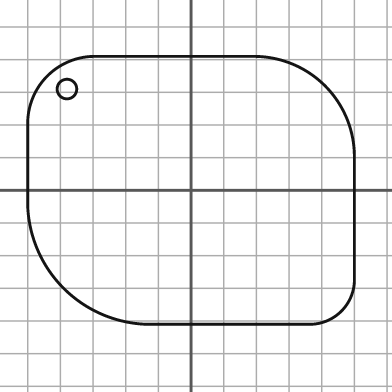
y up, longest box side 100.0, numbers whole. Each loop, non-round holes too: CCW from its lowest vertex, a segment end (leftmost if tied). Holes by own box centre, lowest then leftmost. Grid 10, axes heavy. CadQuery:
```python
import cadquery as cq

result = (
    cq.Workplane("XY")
    .moveTo(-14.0, -41.0)
    .lineTo(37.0, -41.0)
    .threePointArc((46.0, -37.0), (50.0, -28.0))
    .lineTo(50.0, 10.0)
    .threePointArc((41.0, 32.0), (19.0, 41.0))
    .lineTo(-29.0, 41.0)
    .threePointArc((-44.0, 35.0), (-50.0, 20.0))
    .lineTo(-50.0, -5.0)
    .threePointArc((-39.0, -30.0), (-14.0, -41.0))
    .close()
    .moveTo(-38.0, 31.0)
    .circle(3.0)
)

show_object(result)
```